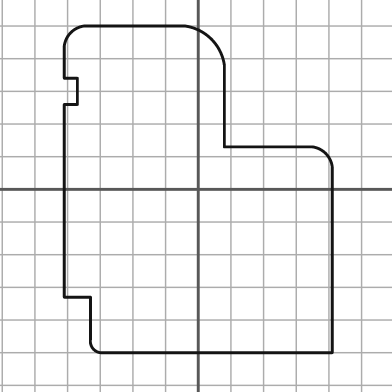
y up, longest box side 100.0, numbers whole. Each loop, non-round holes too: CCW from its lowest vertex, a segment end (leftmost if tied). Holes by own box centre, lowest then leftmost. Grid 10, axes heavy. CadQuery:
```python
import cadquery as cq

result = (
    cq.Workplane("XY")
    .moveTo(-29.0, -50.0)
    .lineTo(41.0, -50.0)
    .lineTo(41.0, 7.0)
    .threePointArc((39.0, 11.0), (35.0, 13.0))
    .lineTo(8.0, 13.0)
    .lineTo(8.0, 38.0)
    .threePointArc((4.0, 46.0), (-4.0, 50.0))
    .lineTo(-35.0, 50.0)
    .threePointArc((-39.0, 48.0), (-41.0, 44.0))
    .lineTo(-41.0, 34.0)
    .lineTo(-37.0, 34.0)
    .lineTo(-37.0, 26.0)
    .lineTo(-41.0, 26.0)
    .lineTo(-41.0, -33.0)
    .lineTo(-33.0, -33.0)
    .lineTo(-33.0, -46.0)
    .threePointArc((-32.0, -49.0), (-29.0, -50.0))
    .close()
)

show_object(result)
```